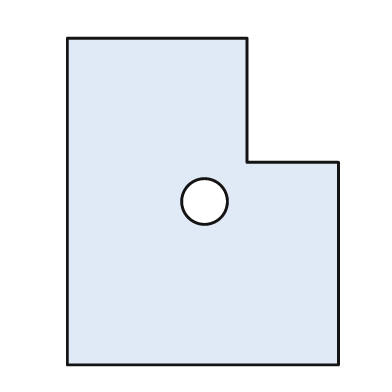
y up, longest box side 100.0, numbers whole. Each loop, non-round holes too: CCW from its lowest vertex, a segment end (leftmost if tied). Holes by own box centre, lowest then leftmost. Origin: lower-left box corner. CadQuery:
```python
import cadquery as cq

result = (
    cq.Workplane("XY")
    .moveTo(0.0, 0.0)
    .lineTo(83.0, 0.0)
    .lineTo(83.0, 62.0)
    .lineTo(55.0, 62.0)
    .lineTo(55.0, 100.0)
    .lineTo(0.0, 100.0)
    .close()
    .moveTo(42.0, 50.0)
    .circle(7.0)
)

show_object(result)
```